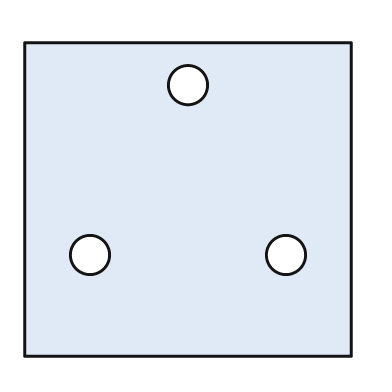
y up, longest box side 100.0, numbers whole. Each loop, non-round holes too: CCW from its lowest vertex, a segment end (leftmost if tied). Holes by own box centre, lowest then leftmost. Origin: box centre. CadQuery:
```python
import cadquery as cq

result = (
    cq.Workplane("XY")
    .moveTo(-50.0, -48.0)
    .lineTo(50.0, -48.0)
    .lineTo(50.0, 48.0)
    .lineTo(-50.0, 48.0)
    .close()
    .moveTo(-30.0, -17.0)
    .circle(6.0)
    .moveTo(30.0, -17.0)
    .circle(6.0)
    .moveTo(0.0, 35.0)
    .circle(6.0)
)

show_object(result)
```